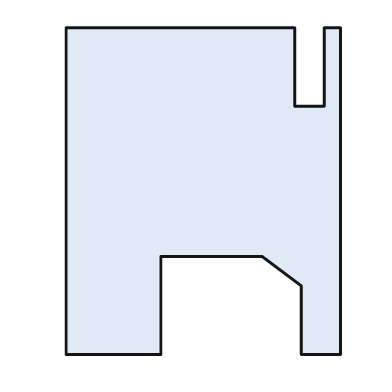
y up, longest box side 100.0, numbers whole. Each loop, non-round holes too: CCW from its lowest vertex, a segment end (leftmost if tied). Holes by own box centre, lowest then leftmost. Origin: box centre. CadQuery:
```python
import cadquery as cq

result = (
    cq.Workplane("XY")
    .moveTo(-42.0, -50.0)
    .lineTo(-13.0, -50.0)
    .lineTo(-13.0, -20.0)
    .lineTo(18.0, -20.0)
    .lineTo(30.0, -29.0)
    .lineTo(30.0, -50.0)
    .lineTo(42.0, -50.0)
    .lineTo(42.0, 50.0)
    .lineTo(37.0, 50.0)
    .lineTo(37.0, 26.0)
    .lineTo(28.0, 26.0)
    .lineTo(28.0, 50.0)
    .lineTo(-42.0, 50.0)
    .close()
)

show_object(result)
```